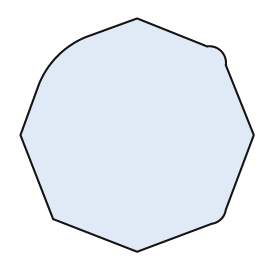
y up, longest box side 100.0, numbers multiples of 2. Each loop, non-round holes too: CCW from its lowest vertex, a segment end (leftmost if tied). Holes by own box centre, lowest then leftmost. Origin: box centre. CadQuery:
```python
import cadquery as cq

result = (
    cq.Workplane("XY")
    .moveTo(0.0, -50.0)
    .lineTo(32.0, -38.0)
    .threePointArc((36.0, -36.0), (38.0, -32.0))
    .lineTo(50.0, 0.0)
    .lineTo(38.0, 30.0)
    .threePointArc((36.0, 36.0), (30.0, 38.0))
    .lineTo(0.0, 50.0)
    .lineTo(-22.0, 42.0)
    .threePointArc((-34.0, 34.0), (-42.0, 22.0))
    .lineTo(-50.0, 0.0)
    .lineTo(-36.0, -36.0)
    .close()
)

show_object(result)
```